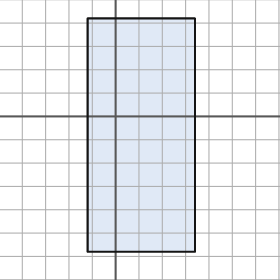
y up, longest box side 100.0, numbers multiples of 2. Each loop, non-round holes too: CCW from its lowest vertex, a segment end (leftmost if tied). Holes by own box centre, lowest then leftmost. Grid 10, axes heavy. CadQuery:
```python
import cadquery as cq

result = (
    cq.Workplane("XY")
    .moveTo(-12.0, -58.0)
    .lineTo(34.0, -58.0)
    .lineTo(34.0, 42.0)
    .lineTo(-12.0, 42.0)
    .close()
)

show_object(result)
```